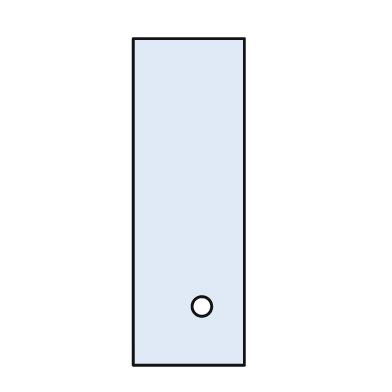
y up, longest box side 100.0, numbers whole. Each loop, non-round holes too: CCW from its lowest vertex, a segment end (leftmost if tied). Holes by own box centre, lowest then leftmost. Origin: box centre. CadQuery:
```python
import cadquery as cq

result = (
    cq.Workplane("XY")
    .moveTo(-17.0, -50.0)
    .lineTo(17.0, -50.0)
    .lineTo(17.0, 50.0)
    .lineTo(-17.0, 50.0)
    .close()
    .moveTo(4.0, -32.0)
    .circle(3.0)
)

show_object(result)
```